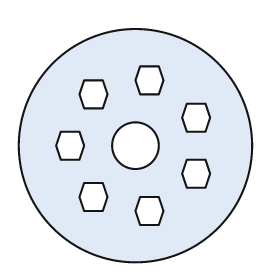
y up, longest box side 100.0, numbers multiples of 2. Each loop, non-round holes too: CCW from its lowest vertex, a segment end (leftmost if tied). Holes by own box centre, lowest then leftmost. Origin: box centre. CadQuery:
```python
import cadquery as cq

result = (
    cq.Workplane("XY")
    .moveTo(0.0, 0.0)
    .circle(50.0)
    .moveTo(2.0, -34.0)
    .lineTo(10.0, -34.0)
    .lineTo(12.0, -28.0)
    .lineTo(10.0, -22.0)
    .lineTo(2.0, -22.0)
    .lineTo(0.0, -28.0)
    .close()
    .moveTo(-22.0, -28.0)
    .lineTo(-14.0, -28.0)
    .lineTo(-12.0, -22.0)
    .lineTo(-14.0, -16.0)
    .lineTo(-22.0, -16.0)
    .lineTo(-24.0, -22.0)
    .close()
    .moveTo(22.0, -18.0)
    .lineTo(30.0, -18.0)
    .lineTo(32.0, -12.0)
    .lineTo(30.0, -6.0)
    .lineTo(22.0, -6.0)
    .lineTo(20.0, -12.0)
    .close()
    .moveTo(-32.0, -6.0)
    .lineTo(-24.0, -6.0)
    .lineTo(-22.0, 0.0)
    .lineTo(-24.0, 6.0)
    .lineTo(-32.0, 6.0)
    .lineTo(-34.0, 0.0)
    .close()
    .moveTo(0.0, 0.0)
    .circle(10.0)
    .moveTo(22.0, 6.0)
    .lineTo(30.0, 6.0)
    .lineTo(32.0, 12.0)
    .lineTo(30.0, 18.0)
    .lineTo(22.0, 18.0)
    .lineTo(20.0, 12.0)
    .close()
    .moveTo(-22.0, 16.0)
    .lineTo(-14.0, 16.0)
    .lineTo(-12.0, 22.0)
    .lineTo(-14.0, 28.0)
    .lineTo(-22.0, 28.0)
    .lineTo(-24.0, 22.0)
    .close()
    .moveTo(2.0, 22.0)
    .lineTo(10.0, 22.0)
    .lineTo(12.0, 28.0)
    .lineTo(10.0, 34.0)
    .lineTo(2.0, 34.0)
    .lineTo(0.0, 28.0)
    .close()
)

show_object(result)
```